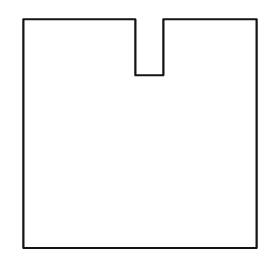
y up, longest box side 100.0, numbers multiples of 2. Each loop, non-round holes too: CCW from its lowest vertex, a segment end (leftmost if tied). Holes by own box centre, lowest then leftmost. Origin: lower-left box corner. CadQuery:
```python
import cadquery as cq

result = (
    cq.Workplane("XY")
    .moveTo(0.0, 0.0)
    .lineTo(100.0, 0.0)
    .lineTo(100.0, 98.0)
    .lineTo(60.0, 98.0)
    .lineTo(60.0, 74.0)
    .lineTo(48.0, 74.0)
    .lineTo(48.0, 98.0)
    .lineTo(0.0, 98.0)
    .close()
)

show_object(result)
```